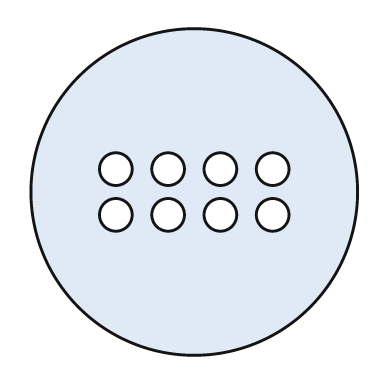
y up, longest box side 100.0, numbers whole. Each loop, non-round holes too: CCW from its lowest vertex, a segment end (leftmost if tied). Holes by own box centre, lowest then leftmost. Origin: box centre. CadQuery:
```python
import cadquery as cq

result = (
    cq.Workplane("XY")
    .moveTo(0.0, 0.0)
    .circle(50.0)
    .moveTo(-24.0, -7.0)
    .circle(5.0)
    .moveTo(-8.0, -7.0)
    .circle(5.0)
    .moveTo(8.0, -7.0)
    .circle(5.0)
    .moveTo(24.0, -7.0)
    .circle(5.0)
    .moveTo(-24.0, 7.0)
    .circle(5.0)
    .moveTo(-8.0, 7.0)
    .circle(5.0)
    .moveTo(8.0, 7.0)
    .circle(5.0)
    .moveTo(24.0, 7.0)
    .circle(5.0)
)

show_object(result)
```